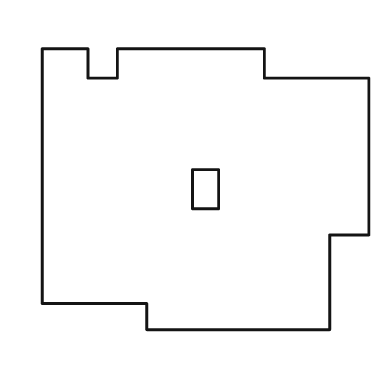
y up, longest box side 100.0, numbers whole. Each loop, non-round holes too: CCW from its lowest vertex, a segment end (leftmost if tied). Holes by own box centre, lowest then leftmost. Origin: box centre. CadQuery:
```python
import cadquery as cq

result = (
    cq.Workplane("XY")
    .moveTo(-18.0, -43.0)
    .lineTo(38.0, -43.0)
    .lineTo(38.0, -14.0)
    .lineTo(50.0, -14.0)
    .lineTo(50.0, 34.0)
    .lineTo(18.0, 34.0)
    .lineTo(18.0, 43.0)
    .lineTo(-27.0, 43.0)
    .lineTo(-27.0, 34.0)
    .lineTo(-36.0, 34.0)
    .lineTo(-36.0, 43.0)
    .lineTo(-50.0, 43.0)
    .lineTo(-50.0, -35.0)
    .lineTo(-18.0, -35.0)
    .close()
    .moveTo(-4.0, -6.0)
    .lineTo(4.0, -6.0)
    .lineTo(4.0, 6.0)
    .lineTo(-4.0, 6.0)
    .close()
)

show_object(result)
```